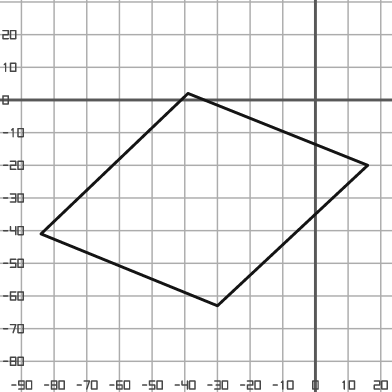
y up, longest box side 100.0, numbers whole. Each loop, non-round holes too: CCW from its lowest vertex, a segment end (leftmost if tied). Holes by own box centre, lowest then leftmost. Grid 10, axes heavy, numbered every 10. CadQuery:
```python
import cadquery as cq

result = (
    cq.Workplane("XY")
    .moveTo(-30.0, -63.0)
    .lineTo(16.0, -20.0)
    .lineTo(-39.0, 2.0)
    .lineTo(-84.0, -41.0)
    .close()
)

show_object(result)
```